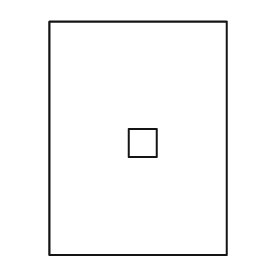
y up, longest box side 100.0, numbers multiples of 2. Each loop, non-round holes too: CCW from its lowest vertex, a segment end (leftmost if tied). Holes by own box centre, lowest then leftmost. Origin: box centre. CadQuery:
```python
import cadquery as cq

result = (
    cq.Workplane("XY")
    .moveTo(-38.0, -50.0)
    .lineTo(38.0, -50.0)
    .lineTo(38.0, 50.0)
    .lineTo(-38.0, 50.0)
    .close()
    .moveTo(-4.0, -8.0)
    .lineTo(8.0, -8.0)
    .lineTo(8.0, 4.0)
    .lineTo(-4.0, 4.0)
    .close()
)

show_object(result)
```